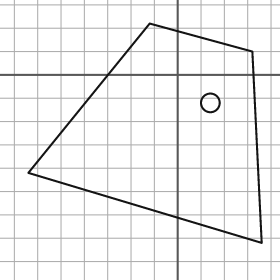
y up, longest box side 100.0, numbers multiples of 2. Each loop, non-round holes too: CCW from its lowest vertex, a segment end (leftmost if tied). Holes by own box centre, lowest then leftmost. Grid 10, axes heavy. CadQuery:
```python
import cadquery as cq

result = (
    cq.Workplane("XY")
    .moveTo(36.0, -72.0)
    .lineTo(32.0, 10.0)
    .lineTo(-12.0, 22.0)
    .lineTo(-64.0, -42.0)
    .close()
    .moveTo(14.0, -12.0)
    .circle(4.0)
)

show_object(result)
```